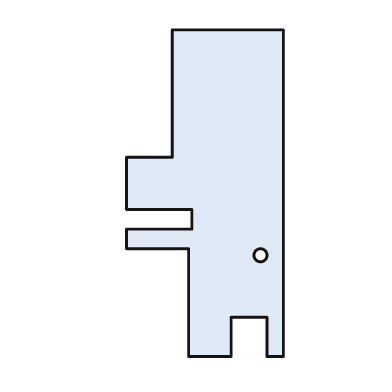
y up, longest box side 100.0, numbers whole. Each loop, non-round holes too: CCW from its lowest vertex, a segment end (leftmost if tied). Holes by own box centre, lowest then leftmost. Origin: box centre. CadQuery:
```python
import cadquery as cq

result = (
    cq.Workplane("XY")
    .moveTo(-5.0, -50.0)
    .lineTo(8.0, -50.0)
    .lineTo(8.0, -38.0)
    .lineTo(19.0, -38.0)
    .lineTo(19.0, -50.0)
    .lineTo(24.0, -50.0)
    .lineTo(24.0, 50.0)
    .lineTo(-10.0, 50.0)
    .lineTo(-10.0, 11.0)
    .lineTo(-24.0, 11.0)
    .lineTo(-24.0, -5.0)
    .lineTo(-4.0, -5.0)
    .lineTo(-4.0, -11.0)
    .lineTo(-24.0, -11.0)
    .lineTo(-24.0, -17.0)
    .lineTo(-5.0, -17.0)
    .close()
    .moveTo(17.0, -19.0)
    .circle(2.0)
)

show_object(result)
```